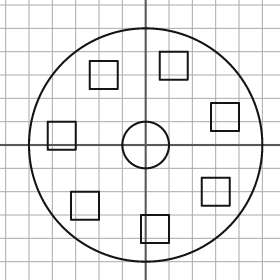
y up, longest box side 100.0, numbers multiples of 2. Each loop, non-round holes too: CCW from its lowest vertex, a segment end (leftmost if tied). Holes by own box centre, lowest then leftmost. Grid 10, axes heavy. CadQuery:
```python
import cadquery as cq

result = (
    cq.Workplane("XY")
    .moveTo(0.0, 0.0)
    .circle(50.0)
    .moveTo(-2.0, -42.0)
    .lineTo(10.0, -42.0)
    .lineTo(10.0, -30.0)
    .lineTo(-2.0, -30.0)
    .close()
    .moveTo(-32.0, -32.0)
    .lineTo(-20.0, -32.0)
    .lineTo(-20.0, -20.0)
    .lineTo(-32.0, -20.0)
    .close()
    .moveTo(24.0, -26.0)
    .lineTo(36.0, -26.0)
    .lineTo(36.0, -14.0)
    .lineTo(24.0, -14.0)
    .close()
    .moveTo(0.0, 0.0)
    .circle(10.0)
    .moveTo(-42.0, -2.0)
    .lineTo(-30.0, -2.0)
    .lineTo(-30.0, 10.0)
    .lineTo(-42.0, 10.0)
    .close()
    .moveTo(28.0, 6.0)
    .lineTo(40.0, 6.0)
    .lineTo(40.0, 18.0)
    .lineTo(28.0, 18.0)
    .close()
    .moveTo(-24.0, 24.0)
    .lineTo(-12.0, 24.0)
    .lineTo(-12.0, 36.0)
    .lineTo(-24.0, 36.0)
    .close()
    .moveTo(6.0, 28.0)
    .lineTo(18.0, 28.0)
    .lineTo(18.0, 40.0)
    .lineTo(6.0, 40.0)
    .close()
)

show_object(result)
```